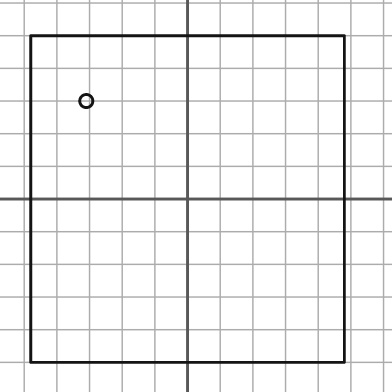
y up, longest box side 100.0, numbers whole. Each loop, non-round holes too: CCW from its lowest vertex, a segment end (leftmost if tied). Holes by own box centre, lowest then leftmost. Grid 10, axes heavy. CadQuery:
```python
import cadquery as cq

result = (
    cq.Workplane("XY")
    .moveTo(-48.0, -50.0)
    .lineTo(48.0, -50.0)
    .lineTo(48.0, 50.0)
    .lineTo(-48.0, 50.0)
    .close()
    .moveTo(-31.0, 30.0)
    .circle(2.0)
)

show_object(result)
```